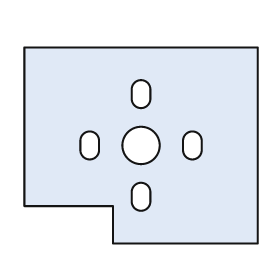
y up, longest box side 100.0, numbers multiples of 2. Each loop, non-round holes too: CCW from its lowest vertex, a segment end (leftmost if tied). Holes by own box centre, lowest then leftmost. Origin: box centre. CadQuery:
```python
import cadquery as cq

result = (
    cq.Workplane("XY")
    .moveTo(-12.0, -42.0)
    .lineTo(50.0, -42.0)
    .lineTo(50.0, 42.0)
    .lineTo(-50.0, 42.0)
    .lineTo(-50.0, -26.0)
    .lineTo(-12.0, -26.0)
    .close()
    .moveTo(-4.0, -24.0)
    .threePointArc((0.0, -28.0), (4.0, -24.0))
    .lineTo(4.0, -20.0)
    .threePointArc((0.0, -16.0), (-4.0, -20.0))
    .close()
    .moveTo(-26.0, -2.0)
    .threePointArc((-22.0, -6.0), (-18.0, -2.0))
    .lineTo(-18.0, 2.0)
    .threePointArc((-22.0, 6.0), (-26.0, 2.0))
    .close()
    .moveTo(0.0, 0.0)
    .circle(8.0)
    .moveTo(18.0, -2.0)
    .threePointArc((22.0, -6.0), (26.0, -2.0))
    .lineTo(26.0, 2.0)
    .threePointArc((22.0, 6.0), (18.0, 2.0))
    .close()
    .moveTo(-4.0, 20.0)
    .threePointArc((0.0, 16.0), (4.0, 20.0))
    .lineTo(4.0, 24.0)
    .threePointArc((0.0, 28.0), (-4.0, 24.0))
    .close()
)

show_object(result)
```